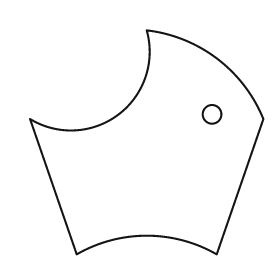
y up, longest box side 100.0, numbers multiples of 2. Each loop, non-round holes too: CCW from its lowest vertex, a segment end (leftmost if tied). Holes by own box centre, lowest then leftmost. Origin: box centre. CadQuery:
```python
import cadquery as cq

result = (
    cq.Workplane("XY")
    .moveTo(-30.0, -48.0)
    .threePointArc((0.0, -40.0), (30.0, -48.0))
    .lineTo(50.0, 10.0)
    .threePointArc((30.0, 36.0), (0.0, 48.0))
    .threePointArc((-12.0, 12.0), (-50.0, 10.0))
    .close()
    .moveTo(28.0, 12.0)
    .circle(4.0)
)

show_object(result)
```